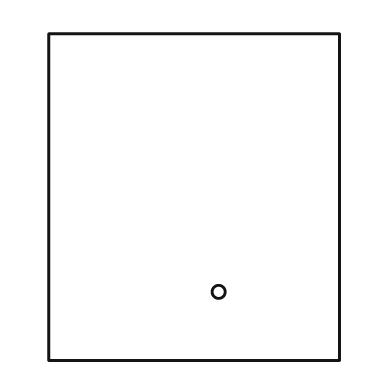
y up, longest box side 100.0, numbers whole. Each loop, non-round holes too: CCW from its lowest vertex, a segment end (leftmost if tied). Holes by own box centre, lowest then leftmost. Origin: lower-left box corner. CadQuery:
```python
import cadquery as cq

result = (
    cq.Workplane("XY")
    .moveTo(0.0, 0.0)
    .lineTo(89.0, 0.0)
    .lineTo(89.0, 100.0)
    .lineTo(0.0, 100.0)
    .close()
    .moveTo(52.0, 21.0)
    .circle(2.0)
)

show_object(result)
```